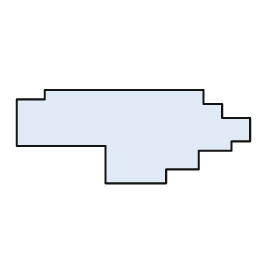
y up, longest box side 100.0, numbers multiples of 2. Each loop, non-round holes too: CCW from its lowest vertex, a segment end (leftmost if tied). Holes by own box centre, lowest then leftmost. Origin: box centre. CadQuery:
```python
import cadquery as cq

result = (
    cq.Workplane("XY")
    .moveTo(-12.0, -20.0)
    .lineTo(14.0, -20.0)
    .lineTo(14.0, -14.0)
    .lineTo(28.0, -14.0)
    .lineTo(28.0, -6.0)
    .lineTo(42.0, -6.0)
    .lineTo(42.0, -2.0)
    .lineTo(50.0, -2.0)
    .lineTo(50.0, 8.0)
    .lineTo(38.0, 8.0)
    .lineTo(38.0, 14.0)
    .lineTo(30.0, 14.0)
    .lineTo(30.0, 20.0)
    .lineTo(-38.0, 20.0)
    .lineTo(-38.0, 16.0)
    .lineTo(-50.0, 16.0)
    .lineTo(-50.0, -4.0)
    .lineTo(-12.0, -4.0)
    .close()
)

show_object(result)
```